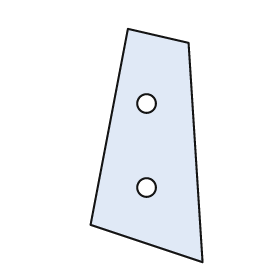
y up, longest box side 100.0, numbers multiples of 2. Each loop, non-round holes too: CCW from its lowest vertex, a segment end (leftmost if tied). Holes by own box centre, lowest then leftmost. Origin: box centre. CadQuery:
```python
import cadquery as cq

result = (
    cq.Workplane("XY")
    .moveTo(24.0, -50.0)
    .lineTo(18.0, 44.0)
    .lineTo(-8.0, 50.0)
    .lineTo(-24.0, -34.0)
    .close()
    .moveTo(0.0, -18.0)
    .circle(4.0)
    .moveTo(0.0, 18.0)
    .circle(4.0)
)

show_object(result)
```